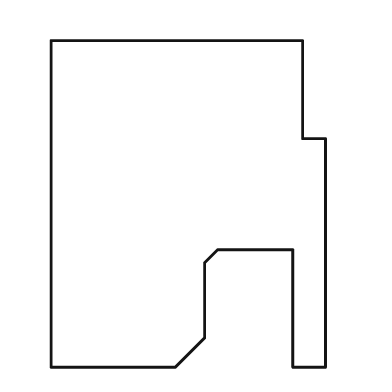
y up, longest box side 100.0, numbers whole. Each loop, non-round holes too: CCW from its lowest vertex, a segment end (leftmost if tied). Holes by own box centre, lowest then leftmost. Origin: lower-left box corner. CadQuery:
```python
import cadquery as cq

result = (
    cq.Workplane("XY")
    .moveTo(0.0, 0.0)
    .lineTo(38.0, 0.0)
    .lineTo(47.0, 9.0)
    .lineTo(47.0, 32.0)
    .lineTo(51.0, 36.0)
    .lineTo(74.0, 36.0)
    .lineTo(74.0, 0.0)
    .lineTo(84.0, 0.0)
    .lineTo(84.0, 70.0)
    .lineTo(77.0, 70.0)
    .lineTo(77.0, 100.0)
    .lineTo(0.0, 100.0)
    .close()
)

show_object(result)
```